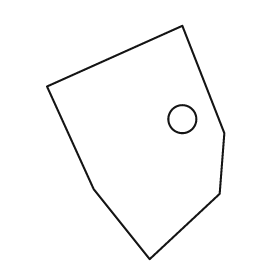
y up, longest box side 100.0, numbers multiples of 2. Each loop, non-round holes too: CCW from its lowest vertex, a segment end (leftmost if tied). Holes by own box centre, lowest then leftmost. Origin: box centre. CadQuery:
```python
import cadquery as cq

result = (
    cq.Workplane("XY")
    .moveTo(6.0, -50.0)
    .lineTo(36.0, -22.0)
    .lineTo(38.0, 4.0)
    .lineTo(20.0, 50.0)
    .lineTo(-38.0, 24.0)
    .lineTo(-18.0, -20.0)
    .close()
    .moveTo(20.0, 10.0)
    .circle(6.0)
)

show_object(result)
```